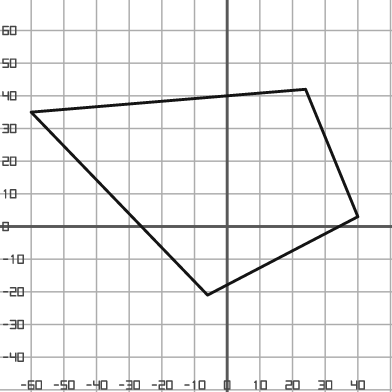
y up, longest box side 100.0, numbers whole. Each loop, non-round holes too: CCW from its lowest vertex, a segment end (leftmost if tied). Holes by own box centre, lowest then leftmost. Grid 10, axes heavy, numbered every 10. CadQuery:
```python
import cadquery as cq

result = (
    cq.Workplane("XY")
    .moveTo(-6.0, -21.0)
    .lineTo(40.0, 3.0)
    .lineTo(24.0, 42.0)
    .lineTo(-60.0, 35.0)
    .close()
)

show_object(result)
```